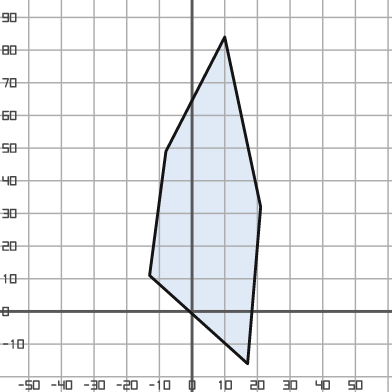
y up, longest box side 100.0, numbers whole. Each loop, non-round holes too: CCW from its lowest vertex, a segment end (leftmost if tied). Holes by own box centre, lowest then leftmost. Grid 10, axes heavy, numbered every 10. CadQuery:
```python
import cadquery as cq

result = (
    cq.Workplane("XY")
    .moveTo(17.0, -16.0)
    .lineTo(21.0, 32.0)
    .lineTo(10.0, 84.0)
    .lineTo(-8.0, 49.0)
    .lineTo(-13.0, 11.0)
    .close()
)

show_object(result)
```